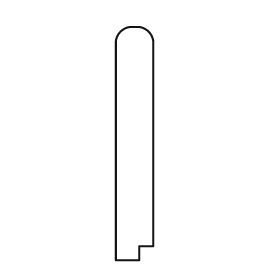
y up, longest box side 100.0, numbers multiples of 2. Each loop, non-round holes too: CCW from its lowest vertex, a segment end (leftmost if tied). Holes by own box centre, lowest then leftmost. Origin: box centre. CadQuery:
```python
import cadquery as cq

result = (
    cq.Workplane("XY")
    .moveTo(-8.0, -50.0)
    .lineTo(2.0, -50.0)
    .lineTo(2.0, -44.0)
    .lineTo(8.0, -44.0)
    .lineTo(8.0, 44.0)
    .threePointArc((6.0, 48.0), (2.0, 50.0))
    .lineTo(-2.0, 50.0)
    .threePointArc((-6.0, 48.0), (-8.0, 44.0))
    .close()
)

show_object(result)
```